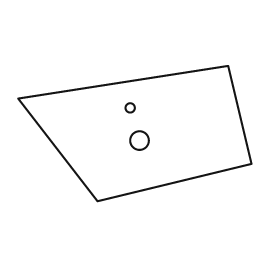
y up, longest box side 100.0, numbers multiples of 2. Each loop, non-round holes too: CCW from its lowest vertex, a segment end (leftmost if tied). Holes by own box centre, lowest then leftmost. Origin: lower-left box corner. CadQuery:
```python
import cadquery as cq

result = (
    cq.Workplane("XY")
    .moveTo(34.0, 0.0)
    .lineTo(100.0, 16.0)
    .lineTo(90.0, 58.0)
    .lineTo(0.0, 44.0)
    .close()
    .moveTo(52.0, 26.0)
    .circle(4.0)
    .moveTo(48.0, 40.0)
    .circle(2.0)
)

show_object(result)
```